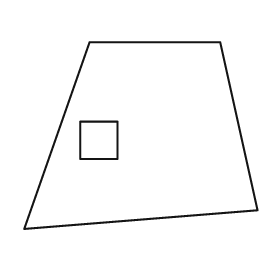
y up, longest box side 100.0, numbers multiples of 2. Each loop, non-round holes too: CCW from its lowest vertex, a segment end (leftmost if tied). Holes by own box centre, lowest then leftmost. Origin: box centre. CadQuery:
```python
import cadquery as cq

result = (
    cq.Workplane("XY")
    .moveTo(-50.0, -40.0)
    .lineTo(50.0, -32.0)
    .lineTo(34.0, 40.0)
    .lineTo(-22.0, 40.0)
    .close()
    .moveTo(-26.0, -10.0)
    .lineTo(-10.0, -10.0)
    .lineTo(-10.0, 6.0)
    .lineTo(-26.0, 6.0)
    .close()
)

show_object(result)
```